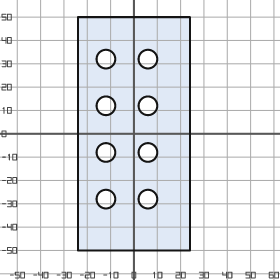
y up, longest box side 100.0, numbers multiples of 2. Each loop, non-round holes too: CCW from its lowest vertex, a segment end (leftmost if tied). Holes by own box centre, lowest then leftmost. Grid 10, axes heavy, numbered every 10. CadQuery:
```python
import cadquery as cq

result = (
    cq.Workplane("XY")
    .moveTo(-24.0, -50.0)
    .lineTo(24.0, -50.0)
    .lineTo(24.0, 50.0)
    .lineTo(-24.0, 50.0)
    .close()
    .moveTo(-12.0, -28.0)
    .circle(4.0)
    .moveTo(6.0, -28.0)
    .circle(4.0)
    .moveTo(-12.0, -8.0)
    .circle(4.0)
    .moveTo(6.0, -8.0)
    .circle(4.0)
    .moveTo(-12.0, 12.0)
    .circle(4.0)
    .moveTo(6.0, 12.0)
    .circle(4.0)
    .moveTo(-12.0, 32.0)
    .circle(4.0)
    .moveTo(6.0, 32.0)
    .circle(4.0)
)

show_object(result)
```